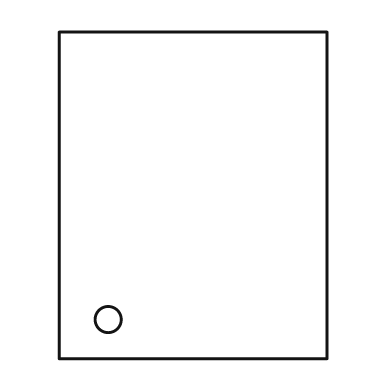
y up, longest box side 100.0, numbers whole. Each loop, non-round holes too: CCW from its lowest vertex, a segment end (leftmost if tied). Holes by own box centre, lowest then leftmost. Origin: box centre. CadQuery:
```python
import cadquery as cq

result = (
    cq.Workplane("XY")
    .moveTo(-41.0, -50.0)
    .lineTo(41.0, -50.0)
    .lineTo(41.0, 50.0)
    .lineTo(-41.0, 50.0)
    .close()
    .moveTo(-26.0, -38.0)
    .circle(4.0)
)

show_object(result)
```